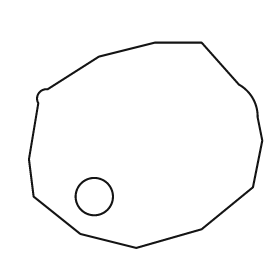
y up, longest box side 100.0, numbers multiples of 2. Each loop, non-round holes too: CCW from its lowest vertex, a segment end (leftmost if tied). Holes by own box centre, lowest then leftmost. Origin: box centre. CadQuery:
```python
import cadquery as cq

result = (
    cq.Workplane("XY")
    .moveTo(-4.0, -44.0)
    .lineTo(24.0, -36.0)
    .lineTo(46.0, -18.0)
    .lineTo(50.0, 2.0)
    .lineTo(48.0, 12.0)
    .threePointArc((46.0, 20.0), (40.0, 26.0))
    .lineTo(24.0, 44.0)
    .lineTo(4.0, 44.0)
    .lineTo(-20.0, 38.0)
    .lineTo(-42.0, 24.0)
    .threePointArc((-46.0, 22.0), (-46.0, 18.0))
    .lineTo(-50.0, -6.0)
    .lineTo(-48.0, -22.0)
    .lineTo(-28.0, -38.0)
    .close()
    .moveTo(-22.0, -22.0)
    .circle(8.0)
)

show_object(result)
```